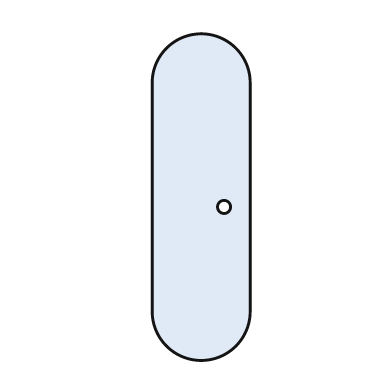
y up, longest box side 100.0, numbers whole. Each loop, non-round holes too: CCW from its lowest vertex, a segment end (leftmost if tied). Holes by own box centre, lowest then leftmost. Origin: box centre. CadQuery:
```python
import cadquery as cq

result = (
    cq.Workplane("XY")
    .moveTo(-15.0, -35.0)
    .threePointArc((0.0, -50.0), (15.0, -35.0))
    .lineTo(15.0, 35.0)
    .threePointArc((0.0, 50.0), (-15.0, 35.0))
    .close()
    .moveTo(7.0, -3.0)
    .circle(2.0)
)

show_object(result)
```